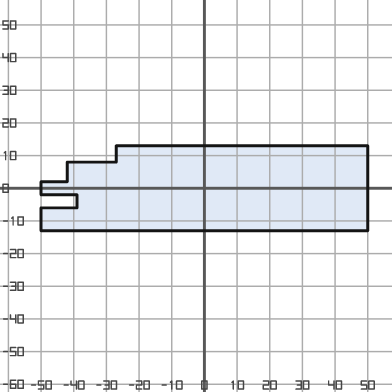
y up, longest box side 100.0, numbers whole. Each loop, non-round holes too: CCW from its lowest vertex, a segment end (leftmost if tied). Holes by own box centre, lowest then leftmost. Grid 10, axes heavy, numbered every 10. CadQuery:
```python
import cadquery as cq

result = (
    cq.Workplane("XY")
    .moveTo(-50.0, -13.0)
    .lineTo(50.0, -13.0)
    .lineTo(50.0, 13.0)
    .lineTo(-27.0, 13.0)
    .lineTo(-27.0, 8.0)
    .lineTo(-42.0, 8.0)
    .lineTo(-42.0, 2.0)
    .lineTo(-50.0, 2.0)
    .lineTo(-50.0, -2.0)
    .lineTo(-39.0, -2.0)
    .lineTo(-39.0, -6.0)
    .lineTo(-50.0, -6.0)
    .close()
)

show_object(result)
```